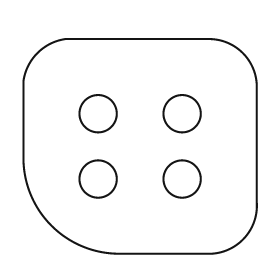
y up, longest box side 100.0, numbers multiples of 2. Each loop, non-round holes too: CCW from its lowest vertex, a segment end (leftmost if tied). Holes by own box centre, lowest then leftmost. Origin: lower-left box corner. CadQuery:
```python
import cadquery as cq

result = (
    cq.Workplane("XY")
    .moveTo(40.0, 0.0)
    .lineTo(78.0, 0.0)
    .threePointArc((94.0, 6.0), (100.0, 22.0))
    .lineTo(100.0, 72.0)
    .threePointArc((94.0, 86.0), (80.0, 92.0))
    .lineTo(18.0, 92.0)
    .threePointArc((6.0, 86.0), (0.0, 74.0))
    .lineTo(0.0, 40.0)
    .threePointArc((12.0, 12.0), (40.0, 0.0))
    .close()
    .moveTo(32.0, 32.0)
    .circle(8.0)
    .moveTo(68.0, 32.0)
    .circle(8.0)
    .moveTo(32.0, 60.0)
    .circle(8.0)
    .moveTo(68.0, 60.0)
    .circle(8.0)
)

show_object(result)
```